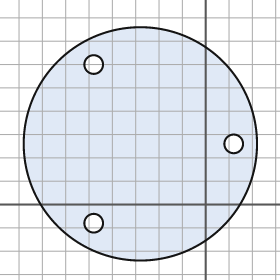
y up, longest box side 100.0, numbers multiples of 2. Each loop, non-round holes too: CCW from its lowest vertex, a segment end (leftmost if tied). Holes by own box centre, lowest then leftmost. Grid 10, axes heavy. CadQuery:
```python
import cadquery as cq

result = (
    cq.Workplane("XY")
    .moveTo(-28.0, 26.0)
    .circle(50.0)
    .moveTo(-48.0, -8.0)
    .circle(4.0)
    .moveTo(12.0, 26.0)
    .circle(4.0)
    .moveTo(-48.0, 60.0)
    .circle(4.0)
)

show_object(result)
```